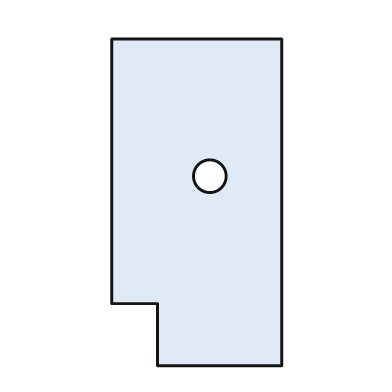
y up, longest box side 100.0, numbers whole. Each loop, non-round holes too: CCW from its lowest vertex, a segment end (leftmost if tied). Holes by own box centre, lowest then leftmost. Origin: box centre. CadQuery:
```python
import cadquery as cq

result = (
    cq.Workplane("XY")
    .moveTo(-12.0, -50.0)
    .lineTo(26.0, -50.0)
    .lineTo(26.0, 50.0)
    .lineTo(-26.0, 50.0)
    .lineTo(-26.0, -31.0)
    .lineTo(-12.0, -31.0)
    .close()
    .moveTo(4.0, 8.0)
    .circle(5.0)
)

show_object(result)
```